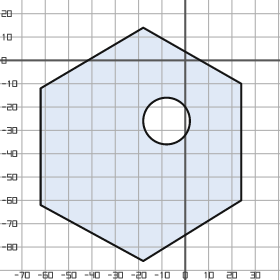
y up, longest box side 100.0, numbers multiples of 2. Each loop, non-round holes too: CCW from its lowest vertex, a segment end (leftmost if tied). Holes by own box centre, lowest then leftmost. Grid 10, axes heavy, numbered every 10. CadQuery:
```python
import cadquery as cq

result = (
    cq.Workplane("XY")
    .moveTo(-18.0, -86.0)
    .lineTo(24.0, -60.0)
    .lineTo(24.0, -10.0)
    .lineTo(-18.0, 14.0)
    .lineTo(-62.0, -12.0)
    .lineTo(-62.0, -62.0)
    .close()
    .moveTo(-8.0, -26.0)
    .circle(10.0)
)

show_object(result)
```